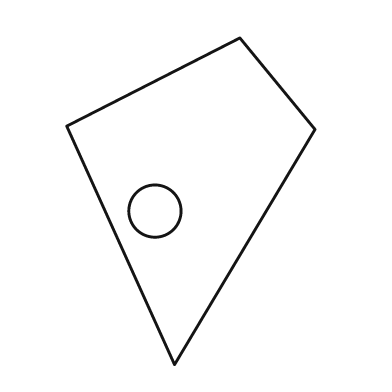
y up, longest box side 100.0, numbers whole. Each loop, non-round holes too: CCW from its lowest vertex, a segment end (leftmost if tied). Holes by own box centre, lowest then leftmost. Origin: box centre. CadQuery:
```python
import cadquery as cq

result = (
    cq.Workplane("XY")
    .moveTo(-5.0, -50.0)
    .lineTo(38.0, 22.0)
    .lineTo(15.0, 50.0)
    .lineTo(-38.0, 23.0)
    .close()
    .moveTo(-11.0, -3.0)
    .circle(8.0)
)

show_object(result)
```